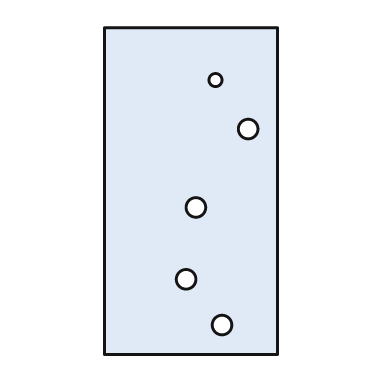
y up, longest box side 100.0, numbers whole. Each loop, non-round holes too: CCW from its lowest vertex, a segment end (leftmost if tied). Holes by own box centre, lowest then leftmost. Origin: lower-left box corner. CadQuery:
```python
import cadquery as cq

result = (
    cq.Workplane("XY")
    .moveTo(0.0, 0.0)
    .lineTo(53.0, 0.0)
    .lineTo(53.0, 100.0)
    .lineTo(0.0, 100.0)
    .close()
    .moveTo(36.0, 9.0)
    .circle(3.0)
    .moveTo(25.0, 23.0)
    .circle(3.0)
    .moveTo(28.0, 45.0)
    .circle(3.0)
    .moveTo(44.0, 69.0)
    .circle(3.0)
    .moveTo(34.0, 84.0)
    .circle(2.0)
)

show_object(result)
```